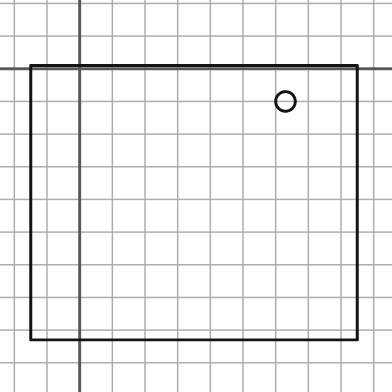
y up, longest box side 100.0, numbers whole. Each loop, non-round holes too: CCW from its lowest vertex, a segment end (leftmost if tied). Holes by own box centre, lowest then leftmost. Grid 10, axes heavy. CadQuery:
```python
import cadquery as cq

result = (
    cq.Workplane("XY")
    .moveTo(-15.0, -83.0)
    .lineTo(85.0, -83.0)
    .lineTo(85.0, 1.0)
    .lineTo(-15.0, 1.0)
    .close()
    .moveTo(63.0, -10.0)
    .circle(3.0)
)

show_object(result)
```